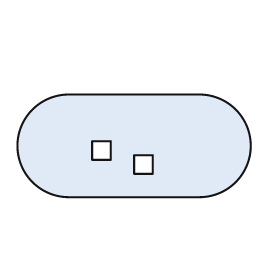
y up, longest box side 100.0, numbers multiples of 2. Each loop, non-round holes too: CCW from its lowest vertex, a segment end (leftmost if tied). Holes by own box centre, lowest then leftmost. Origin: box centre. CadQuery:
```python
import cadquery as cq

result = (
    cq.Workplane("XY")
    .moveTo(-28.0, -22.0)
    .lineTo(28.0, -22.0)
    .threePointArc((50.0, 0.0), (28.0, 22.0))
    .lineTo(-28.0, 22.0)
    .threePointArc((-50.0, 0.0), (-28.0, -22.0))
    .close()
    .moveTo(0.0, -12.0)
    .lineTo(8.0, -12.0)
    .lineTo(8.0, -4.0)
    .lineTo(0.0, -4.0)
    .close()
    .moveTo(-18.0, -6.0)
    .lineTo(-10.0, -6.0)
    .lineTo(-10.0, 2.0)
    .lineTo(-18.0, 2.0)
    .close()
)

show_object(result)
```